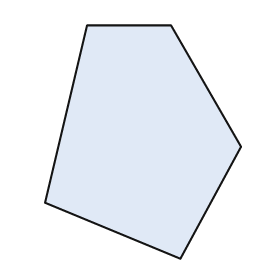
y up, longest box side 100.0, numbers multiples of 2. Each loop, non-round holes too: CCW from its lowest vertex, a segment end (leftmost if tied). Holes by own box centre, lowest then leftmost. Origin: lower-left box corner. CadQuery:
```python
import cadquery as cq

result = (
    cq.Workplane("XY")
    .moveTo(58.0, 0.0)
    .lineTo(84.0, 48.0)
    .lineTo(54.0, 100.0)
    .lineTo(18.0, 100.0)
    .lineTo(0.0, 24.0)
    .close()
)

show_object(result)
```